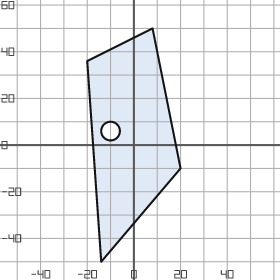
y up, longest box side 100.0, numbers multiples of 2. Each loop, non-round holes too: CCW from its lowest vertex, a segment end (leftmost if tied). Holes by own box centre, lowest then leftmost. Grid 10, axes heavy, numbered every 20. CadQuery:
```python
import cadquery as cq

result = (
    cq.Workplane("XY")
    .moveTo(-14.0, -50.0)
    .lineTo(20.0, -10.0)
    .lineTo(8.0, 50.0)
    .lineTo(-20.0, 36.0)
    .close()
    .moveTo(-10.0, 6.0)
    .circle(4.0)
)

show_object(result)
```